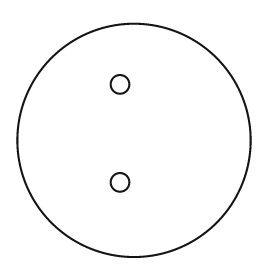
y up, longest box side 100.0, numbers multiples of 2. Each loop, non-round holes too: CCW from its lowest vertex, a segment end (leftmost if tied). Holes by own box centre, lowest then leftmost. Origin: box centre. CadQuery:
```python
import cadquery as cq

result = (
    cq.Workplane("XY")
    .moveTo(0.0, 0.0)
    .circle(50.0)
    .moveTo(-6.0, -18.0)
    .circle(4.0)
    .moveTo(-6.0, 24.0)
    .circle(4.0)
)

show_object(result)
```